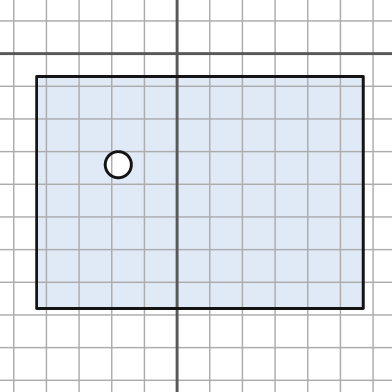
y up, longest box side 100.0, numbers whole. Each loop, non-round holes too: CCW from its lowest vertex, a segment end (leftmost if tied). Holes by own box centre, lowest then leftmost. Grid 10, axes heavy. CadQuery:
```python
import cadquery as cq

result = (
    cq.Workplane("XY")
    .moveTo(-43.0, -78.0)
    .lineTo(57.0, -78.0)
    .lineTo(57.0, -7.0)
    .lineTo(-43.0, -7.0)
    .close()
    .moveTo(-18.0, -34.0)
    .circle(4.0)
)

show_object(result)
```